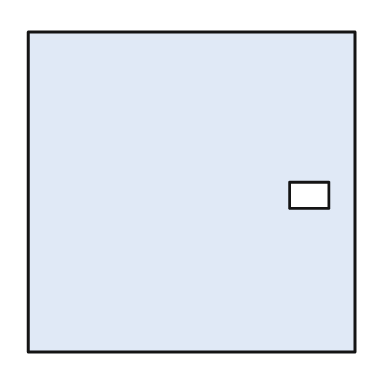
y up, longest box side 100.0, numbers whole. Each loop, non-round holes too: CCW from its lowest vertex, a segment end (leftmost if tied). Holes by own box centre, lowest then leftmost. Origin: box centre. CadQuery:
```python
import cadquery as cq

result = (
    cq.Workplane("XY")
    .moveTo(-50.0, -49.0)
    .lineTo(50.0, -49.0)
    .lineTo(50.0, 49.0)
    .lineTo(-50.0, 49.0)
    .close()
    .moveTo(30.0, -5.0)
    .lineTo(42.0, -5.0)
    .lineTo(42.0, 3.0)
    .lineTo(30.0, 3.0)
    .close()
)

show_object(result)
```